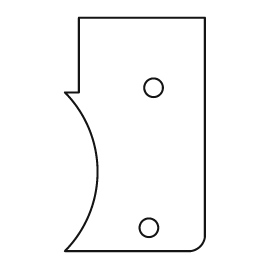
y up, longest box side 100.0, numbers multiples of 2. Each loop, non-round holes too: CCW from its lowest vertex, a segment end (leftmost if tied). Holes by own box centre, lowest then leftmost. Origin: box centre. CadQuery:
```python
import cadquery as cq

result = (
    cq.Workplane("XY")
    .moveTo(-30.0, -50.0)
    .lineTo(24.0, -50.0)
    .threePointArc((28.0, -48.0), (30.0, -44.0))
    .lineTo(30.0, 50.0)
    .lineTo(-24.0, 50.0)
    .lineTo(-24.0, 18.0)
    .lineTo(-30.0, 18.0)
    .threePointArc((-16.0, -16.0), (-30.0, -50.0))
    .close()
    .moveTo(6.0, -40.0)
    .circle(4.0)
    .moveTo(8.0, 20.0)
    .circle(4.0)
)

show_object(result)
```